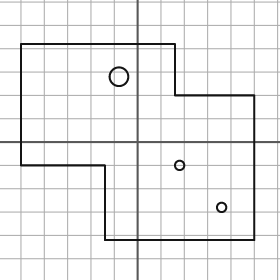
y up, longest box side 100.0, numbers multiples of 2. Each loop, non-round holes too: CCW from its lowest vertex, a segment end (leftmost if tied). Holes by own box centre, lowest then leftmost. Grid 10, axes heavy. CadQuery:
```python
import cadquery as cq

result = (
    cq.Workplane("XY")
    .moveTo(-14.0, -42.0)
    .lineTo(50.0, -42.0)
    .lineTo(50.0, 20.0)
    .lineTo(16.0, 20.0)
    .lineTo(16.0, 42.0)
    .lineTo(-50.0, 42.0)
    .lineTo(-50.0, -10.0)
    .lineTo(-14.0, -10.0)
    .close()
    .moveTo(36.0, -28.0)
    .circle(2.0)
    .moveTo(18.0, -10.0)
    .circle(2.0)
    .moveTo(-8.0, 28.0)
    .circle(4.0)
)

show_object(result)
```